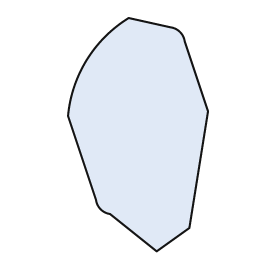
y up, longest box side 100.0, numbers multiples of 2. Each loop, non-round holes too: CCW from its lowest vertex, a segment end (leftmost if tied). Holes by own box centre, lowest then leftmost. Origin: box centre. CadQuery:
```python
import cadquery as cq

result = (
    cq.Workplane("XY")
    .moveTo(8.0, -50.0)
    .lineTo(22.0, -40.0)
    .lineTo(30.0, 10.0)
    .lineTo(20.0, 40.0)
    .threePointArc((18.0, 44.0), (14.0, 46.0))
    .lineTo(-4.0, 50.0)
    .threePointArc((-22.0, 32.0), (-30.0, 8.0))
    .lineTo(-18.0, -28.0)
    .threePointArc((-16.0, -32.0), (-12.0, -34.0))
    .close()
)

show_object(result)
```